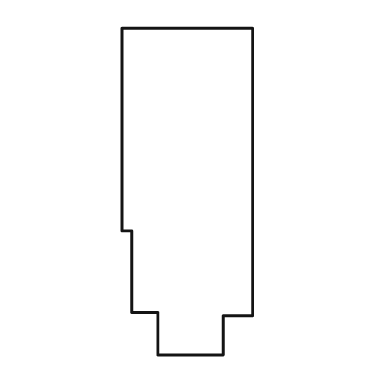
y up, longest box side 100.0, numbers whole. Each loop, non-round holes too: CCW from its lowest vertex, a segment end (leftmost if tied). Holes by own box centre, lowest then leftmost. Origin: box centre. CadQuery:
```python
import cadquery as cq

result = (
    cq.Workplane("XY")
    .moveTo(-9.0, -50.0)
    .lineTo(11.0, -50.0)
    .lineTo(11.0, -38.0)
    .lineTo(20.0, -38.0)
    .lineTo(20.0, 50.0)
    .lineTo(-20.0, 50.0)
    .lineTo(-20.0, -12.0)
    .lineTo(-17.0, -12.0)
    .lineTo(-17.0, -37.0)
    .lineTo(-9.0, -37.0)
    .close()
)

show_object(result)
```